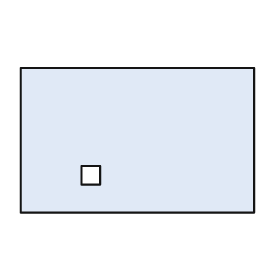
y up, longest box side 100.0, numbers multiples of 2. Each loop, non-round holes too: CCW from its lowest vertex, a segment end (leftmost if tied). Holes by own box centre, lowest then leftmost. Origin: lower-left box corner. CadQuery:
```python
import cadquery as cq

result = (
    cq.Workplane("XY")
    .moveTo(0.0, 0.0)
    .lineTo(100.0, 0.0)
    .lineTo(100.0, 62.0)
    .lineTo(0.0, 62.0)
    .close()
    .moveTo(26.0, 12.0)
    .lineTo(34.0, 12.0)
    .lineTo(34.0, 20.0)
    .lineTo(26.0, 20.0)
    .close()
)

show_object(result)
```